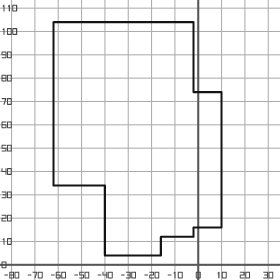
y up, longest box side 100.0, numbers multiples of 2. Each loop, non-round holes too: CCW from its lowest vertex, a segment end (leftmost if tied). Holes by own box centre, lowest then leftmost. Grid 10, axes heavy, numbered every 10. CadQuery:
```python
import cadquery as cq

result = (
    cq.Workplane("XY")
    .moveTo(-40.0, 4.0)
    .lineTo(-16.0, 4.0)
    .lineTo(-16.0, 12.0)
    .lineTo(-2.0, 12.0)
    .lineTo(-2.0, 16.0)
    .lineTo(10.0, 16.0)
    .lineTo(10.0, 74.0)
    .lineTo(-2.0, 74.0)
    .lineTo(-2.0, 104.0)
    .lineTo(-62.0, 104.0)
    .lineTo(-62.0, 34.0)
    .lineTo(-40.0, 34.0)
    .close()
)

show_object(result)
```